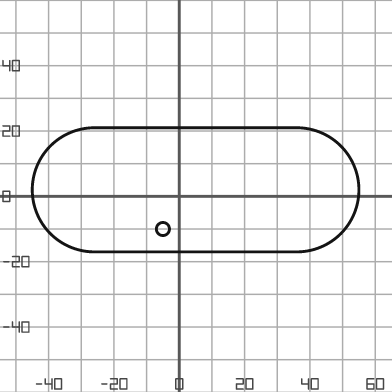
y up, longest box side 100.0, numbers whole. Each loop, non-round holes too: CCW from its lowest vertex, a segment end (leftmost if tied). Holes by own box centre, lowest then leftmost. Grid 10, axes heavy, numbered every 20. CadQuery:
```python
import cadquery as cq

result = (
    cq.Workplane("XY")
    .moveTo(-26.0, -17.0)
    .lineTo(36.0, -17.0)
    .threePointArc((55.0, 2.0), (36.0, 21.0))
    .lineTo(-26.0, 21.0)
    .threePointArc((-45.0, 2.0), (-26.0, -17.0))
    .close()
    .moveTo(-5.0, -10.0)
    .circle(2.0)
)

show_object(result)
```